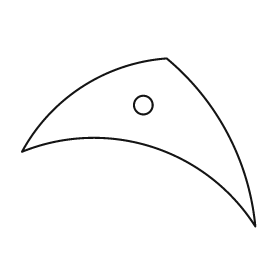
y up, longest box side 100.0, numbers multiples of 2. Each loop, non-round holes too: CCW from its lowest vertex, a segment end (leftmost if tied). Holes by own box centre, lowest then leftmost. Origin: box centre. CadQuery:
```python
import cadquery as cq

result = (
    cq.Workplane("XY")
    .moveTo(50.0, -36.0)
    .threePointArc((38.0, 4.0), (12.0, 36.0))
    .threePointArc((-24.0, 24.0), (-50.0, -4.0))
    .threePointArc((6.0, -2.0), (50.0, -36.0))
    .close()
    .moveTo(2.0, 16.0)
    .circle(4.0)
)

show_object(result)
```